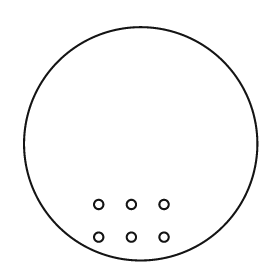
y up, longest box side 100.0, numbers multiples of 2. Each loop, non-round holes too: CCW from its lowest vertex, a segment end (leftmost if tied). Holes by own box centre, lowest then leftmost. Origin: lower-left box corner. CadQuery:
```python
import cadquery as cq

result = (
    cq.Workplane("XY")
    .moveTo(50.0, 50.0)
    .circle(50.0)
    .moveTo(32.0, 10.0)
    .circle(2.0)
    .moveTo(46.0, 10.0)
    .circle(2.0)
    .moveTo(60.0, 10.0)
    .circle(2.0)
    .moveTo(32.0, 24.0)
    .circle(2.0)
    .moveTo(46.0, 24.0)
    .circle(2.0)
    .moveTo(60.0, 24.0)
    .circle(2.0)
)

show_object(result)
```